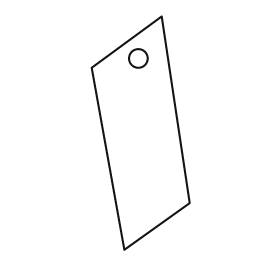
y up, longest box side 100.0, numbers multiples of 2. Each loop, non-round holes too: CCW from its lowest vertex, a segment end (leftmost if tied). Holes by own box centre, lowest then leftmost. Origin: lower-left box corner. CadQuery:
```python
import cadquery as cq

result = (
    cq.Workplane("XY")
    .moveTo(14.0, 0.0)
    .lineTo(42.0, 20.0)
    .lineTo(30.0, 100.0)
    .lineTo(0.0, 78.0)
    .close()
    .moveTo(20.0, 82.0)
    .circle(4.0)
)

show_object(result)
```